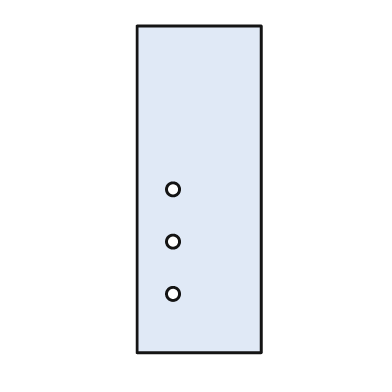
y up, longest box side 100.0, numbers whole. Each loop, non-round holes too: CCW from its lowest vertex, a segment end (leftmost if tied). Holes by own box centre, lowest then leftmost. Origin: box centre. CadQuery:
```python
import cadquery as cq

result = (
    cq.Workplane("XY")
    .moveTo(-19.0, -50.0)
    .lineTo(19.0, -50.0)
    .lineTo(19.0, 50.0)
    .lineTo(-19.0, 50.0)
    .close()
    .moveTo(-8.0, -32.0)
    .circle(2.0)
    .moveTo(-8.0, -16.0)
    .circle(2.0)
    .moveTo(-8.0, 0.0)
    .circle(2.0)
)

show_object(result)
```